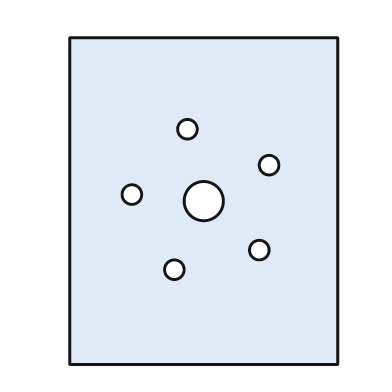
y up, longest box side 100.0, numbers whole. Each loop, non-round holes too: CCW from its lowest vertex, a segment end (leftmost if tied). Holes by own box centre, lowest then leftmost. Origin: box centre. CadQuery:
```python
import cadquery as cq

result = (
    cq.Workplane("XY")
    .moveTo(-41.0, -50.0)
    .lineTo(41.0, -50.0)
    .lineTo(41.0, 50.0)
    .lineTo(-41.0, 50.0)
    .close()
    .moveTo(-9.0, -21.0)
    .circle(3.0)
    .moveTo(17.0, -15.0)
    .circle(3.0)
    .moveTo(0.0, 0.0)
    .circle(6.0)
    .moveTo(-22.0, 2.0)
    .circle(3.0)
    .moveTo(20.0, 11.0)
    .circle(3.0)
    .moveTo(-5.0, 22.0)
    .circle(3.0)
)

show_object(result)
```